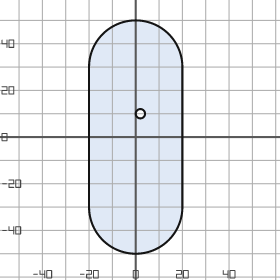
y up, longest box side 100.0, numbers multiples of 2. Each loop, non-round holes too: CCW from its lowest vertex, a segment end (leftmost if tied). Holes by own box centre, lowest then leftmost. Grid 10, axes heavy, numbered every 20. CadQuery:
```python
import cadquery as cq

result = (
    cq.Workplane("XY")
    .moveTo(-20.0, -30.0)
    .threePointArc((0.0, -50.0), (20.0, -30.0))
    .lineTo(20.0, 30.0)
    .threePointArc((0.0, 50.0), (-20.0, 30.0))
    .close()
    .moveTo(2.0, 10.0)
    .circle(2.0)
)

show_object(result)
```